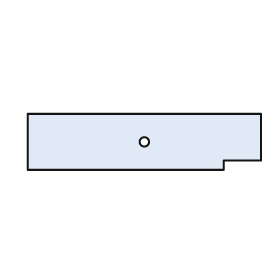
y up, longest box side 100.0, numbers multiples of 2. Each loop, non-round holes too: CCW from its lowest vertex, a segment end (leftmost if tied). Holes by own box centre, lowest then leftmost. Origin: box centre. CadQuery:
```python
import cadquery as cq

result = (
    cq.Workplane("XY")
    .moveTo(-50.0, -12.0)
    .lineTo(34.0, -12.0)
    .lineTo(34.0, -8.0)
    .lineTo(50.0, -8.0)
    .lineTo(50.0, 12.0)
    .lineTo(-50.0, 12.0)
    .close()
    .moveTo(0.0, 0.0)
    .circle(2.0)
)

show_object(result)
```